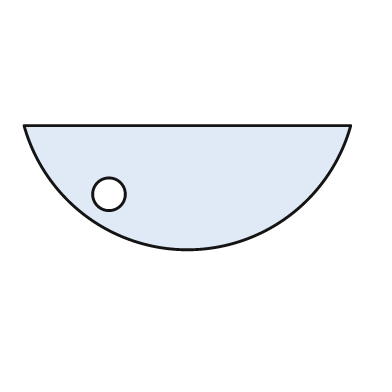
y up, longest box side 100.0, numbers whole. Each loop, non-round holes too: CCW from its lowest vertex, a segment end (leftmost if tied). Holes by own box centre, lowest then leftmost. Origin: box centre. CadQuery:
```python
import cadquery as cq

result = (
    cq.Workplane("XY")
    .moveTo(-50.0, 19.0)
    .threePointArc((0.0, -19.0), (50.0, 19.0))
    .close()
    .moveTo(-24.0, -2.0)
    .circle(5.0)
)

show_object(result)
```